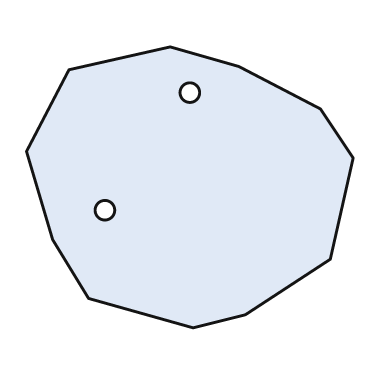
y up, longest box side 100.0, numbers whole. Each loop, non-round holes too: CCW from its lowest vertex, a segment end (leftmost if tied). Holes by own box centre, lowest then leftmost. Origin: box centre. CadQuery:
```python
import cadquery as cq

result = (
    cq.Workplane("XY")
    .moveTo(1.0, -43.0)
    .lineTo(17.0, -39.0)
    .lineTo(43.0, -22.0)
    .lineTo(50.0, 9.0)
    .lineTo(40.0, 24.0)
    .lineTo(15.0, 37.0)
    .lineTo(-6.0, 43.0)
    .lineTo(-37.0, 36.0)
    .lineTo(-50.0, 11.0)
    .lineTo(-42.0, -16.0)
    .lineTo(-31.0, -34.0)
    .close()
    .moveTo(-26.0, -7.0)
    .circle(3.0)
    .moveTo(0.0, 29.0)
    .circle(3.0)
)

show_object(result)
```